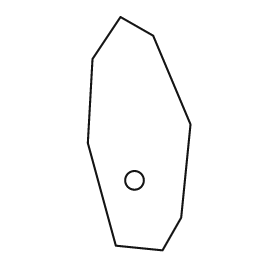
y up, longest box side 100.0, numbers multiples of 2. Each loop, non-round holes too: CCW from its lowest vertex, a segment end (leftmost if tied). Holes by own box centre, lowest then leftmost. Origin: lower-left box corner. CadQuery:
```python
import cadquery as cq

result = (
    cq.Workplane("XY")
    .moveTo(32.0, 0.0)
    .lineTo(40.0, 14.0)
    .lineTo(44.0, 54.0)
    .lineTo(28.0, 92.0)
    .lineTo(14.0, 100.0)
    .lineTo(2.0, 82.0)
    .lineTo(0.0, 46.0)
    .lineTo(12.0, 2.0)
    .close()
    .moveTo(20.0, 30.0)
    .circle(4.0)
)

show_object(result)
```